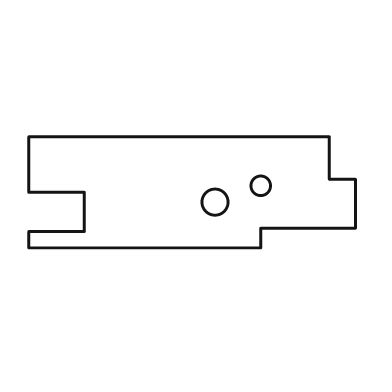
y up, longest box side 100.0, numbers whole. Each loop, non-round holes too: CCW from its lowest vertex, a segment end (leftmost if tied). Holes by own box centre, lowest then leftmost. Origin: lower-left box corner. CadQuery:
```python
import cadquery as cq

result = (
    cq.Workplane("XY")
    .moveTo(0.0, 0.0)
    .lineTo(71.0, 0.0)
    .lineTo(71.0, 6.0)
    .lineTo(100.0, 6.0)
    .lineTo(100.0, 21.0)
    .lineTo(92.0, 21.0)
    .lineTo(92.0, 34.0)
    .lineTo(0.0, 34.0)
    .lineTo(0.0, 17.0)
    .lineTo(17.0, 17.0)
    .lineTo(17.0, 5.0)
    .lineTo(0.0, 5.0)
    .close()
    .moveTo(57.0, 14.0)
    .circle(4.0)
    .moveTo(71.0, 19.0)
    .circle(3.0)
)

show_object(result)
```